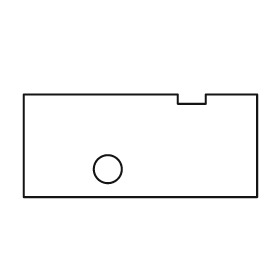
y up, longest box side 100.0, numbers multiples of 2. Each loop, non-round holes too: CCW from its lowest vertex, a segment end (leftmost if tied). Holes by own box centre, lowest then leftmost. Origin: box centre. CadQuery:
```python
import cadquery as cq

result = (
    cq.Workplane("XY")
    .moveTo(-50.0, -22.0)
    .lineTo(50.0, -22.0)
    .lineTo(50.0, 22.0)
    .lineTo(28.0, 22.0)
    .lineTo(28.0, 18.0)
    .lineTo(16.0, 18.0)
    .lineTo(16.0, 22.0)
    .lineTo(-50.0, 22.0)
    .close()
    .moveTo(-14.0, -10.0)
    .circle(6.0)
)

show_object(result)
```